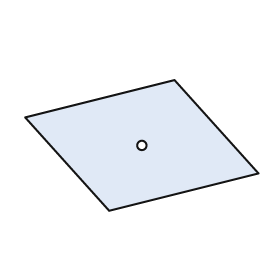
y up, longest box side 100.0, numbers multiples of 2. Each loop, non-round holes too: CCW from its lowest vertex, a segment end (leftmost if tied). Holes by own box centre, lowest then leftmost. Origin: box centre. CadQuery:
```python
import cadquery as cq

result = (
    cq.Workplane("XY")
    .moveTo(-14.0, -28.0)
    .lineTo(50.0, -12.0)
    .lineTo(14.0, 28.0)
    .lineTo(-50.0, 12.0)
    .close()
    .moveTo(0.0, 0.0)
    .circle(2.0)
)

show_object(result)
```